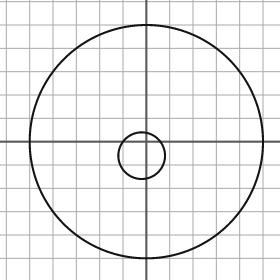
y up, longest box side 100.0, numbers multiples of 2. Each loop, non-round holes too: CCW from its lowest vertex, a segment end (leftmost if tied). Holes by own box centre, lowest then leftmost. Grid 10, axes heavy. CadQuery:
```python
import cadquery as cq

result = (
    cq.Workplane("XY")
    .moveTo(0.0, 0.0)
    .circle(50.0)
    .moveTo(-2.0, -6.0)
    .circle(10.0)
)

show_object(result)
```